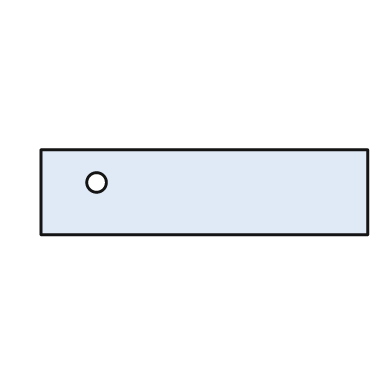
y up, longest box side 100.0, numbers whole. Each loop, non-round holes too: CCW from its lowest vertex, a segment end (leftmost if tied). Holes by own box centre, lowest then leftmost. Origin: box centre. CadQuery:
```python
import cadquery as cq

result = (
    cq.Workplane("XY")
    .moveTo(-50.0, -13.0)
    .lineTo(50.0, -13.0)
    .lineTo(50.0, 13.0)
    .lineTo(-50.0, 13.0)
    .close()
    .moveTo(-33.0, 3.0)
    .circle(3.0)
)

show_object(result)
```